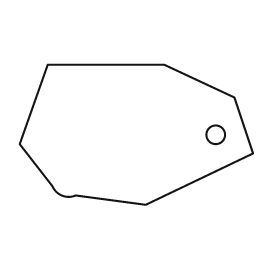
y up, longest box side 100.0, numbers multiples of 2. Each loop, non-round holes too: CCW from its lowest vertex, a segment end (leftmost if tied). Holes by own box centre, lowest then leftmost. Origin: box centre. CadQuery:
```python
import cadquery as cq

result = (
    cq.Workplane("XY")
    .moveTo(4.0, -30.0)
    .lineTo(50.0, -8.0)
    .lineTo(42.0, 16.0)
    .lineTo(12.0, 30.0)
    .lineTo(-38.0, 30.0)
    .lineTo(-50.0, -4.0)
    .lineTo(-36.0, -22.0)
    .threePointArc((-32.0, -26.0), (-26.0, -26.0))
    .close()
    .moveTo(34.0, 0.0)
    .circle(4.0)
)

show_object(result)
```